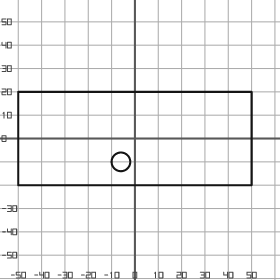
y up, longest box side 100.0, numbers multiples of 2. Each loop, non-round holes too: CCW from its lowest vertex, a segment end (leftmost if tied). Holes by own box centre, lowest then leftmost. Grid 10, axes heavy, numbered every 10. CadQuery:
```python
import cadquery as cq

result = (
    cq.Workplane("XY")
    .moveTo(-50.0, -20.0)
    .lineTo(50.0, -20.0)
    .lineTo(50.0, 20.0)
    .lineTo(-50.0, 20.0)
    .close()
    .moveTo(-6.0, -10.0)
    .circle(4.0)
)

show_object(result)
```